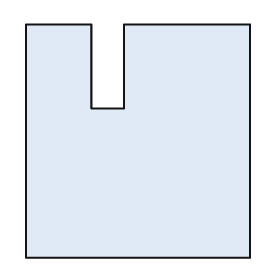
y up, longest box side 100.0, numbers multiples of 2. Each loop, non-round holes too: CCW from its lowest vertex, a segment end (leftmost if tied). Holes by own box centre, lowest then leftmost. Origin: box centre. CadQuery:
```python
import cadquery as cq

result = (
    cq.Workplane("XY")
    .moveTo(-48.0, -50.0)
    .lineTo(48.0, -50.0)
    .lineTo(48.0, 50.0)
    .lineTo(-6.0, 50.0)
    .lineTo(-6.0, 14.0)
    .lineTo(-20.0, 14.0)
    .lineTo(-20.0, 50.0)
    .lineTo(-48.0, 50.0)
    .close()
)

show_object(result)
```